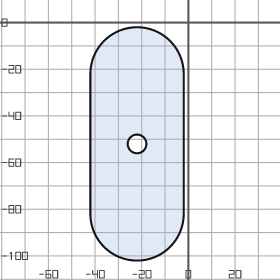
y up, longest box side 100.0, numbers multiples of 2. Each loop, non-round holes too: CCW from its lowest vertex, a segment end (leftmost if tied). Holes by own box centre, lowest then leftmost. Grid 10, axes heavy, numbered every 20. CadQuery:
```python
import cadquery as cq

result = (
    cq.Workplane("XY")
    .moveTo(-42.0, -82.0)
    .threePointArc((-22.0, -102.0), (-2.0, -82.0))
    .lineTo(-2.0, -22.0)
    .threePointArc((-22.0, -2.0), (-42.0, -22.0))
    .close()
    .moveTo(-22.0, -52.0)
    .circle(4.0)
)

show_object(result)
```